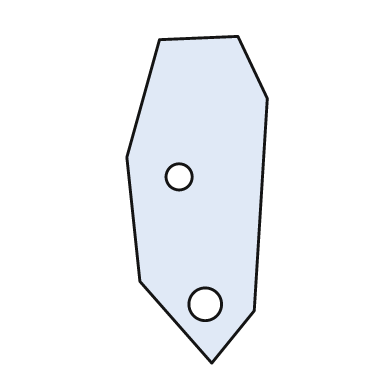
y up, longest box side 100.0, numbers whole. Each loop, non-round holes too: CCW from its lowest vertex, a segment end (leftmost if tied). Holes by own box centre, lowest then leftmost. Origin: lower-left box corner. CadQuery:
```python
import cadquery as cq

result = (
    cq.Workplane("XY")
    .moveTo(26.0, 0.0)
    .lineTo(39.0, 16.0)
    .lineTo(43.0, 81.0)
    .lineTo(34.0, 100.0)
    .lineTo(10.0, 99.0)
    .lineTo(0.0, 63.0)
    .lineTo(4.0, 25.0)
    .close()
    .moveTo(24.0, 18.0)
    .circle(5.0)
    .moveTo(16.0, 57.0)
    .circle(4.0)
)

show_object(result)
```